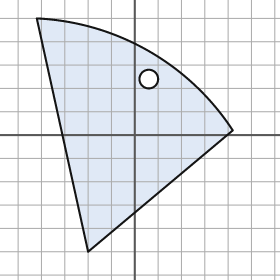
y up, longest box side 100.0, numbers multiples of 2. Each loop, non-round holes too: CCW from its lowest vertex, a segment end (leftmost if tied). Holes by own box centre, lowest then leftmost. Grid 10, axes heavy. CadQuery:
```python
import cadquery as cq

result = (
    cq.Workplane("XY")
    .moveTo(-20.0, -50.0)
    .lineTo(42.0, 2.0)
    .threePointArc((6.0, 36.0), (-42.0, 50.0))
    .close()
    .moveTo(6.0, 24.0)
    .circle(4.0)
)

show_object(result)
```